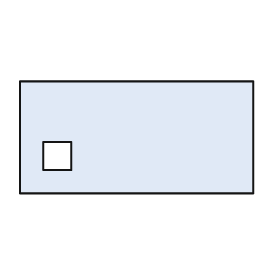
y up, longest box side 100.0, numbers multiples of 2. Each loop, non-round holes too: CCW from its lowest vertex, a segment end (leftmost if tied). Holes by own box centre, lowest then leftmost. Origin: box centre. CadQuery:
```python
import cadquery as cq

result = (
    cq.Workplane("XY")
    .moveTo(-50.0, -24.0)
    .lineTo(50.0, -24.0)
    .lineTo(50.0, 24.0)
    .lineTo(-50.0, 24.0)
    .close()
    .moveTo(-40.0, -14.0)
    .lineTo(-28.0, -14.0)
    .lineTo(-28.0, -2.0)
    .lineTo(-40.0, -2.0)
    .close()
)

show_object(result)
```